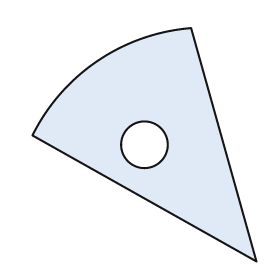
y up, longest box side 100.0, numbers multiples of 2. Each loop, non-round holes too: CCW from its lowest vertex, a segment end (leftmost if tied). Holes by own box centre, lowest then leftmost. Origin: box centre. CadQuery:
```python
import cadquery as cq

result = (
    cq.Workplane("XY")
    .moveTo(48.0, -50.0)
    .lineTo(20.0, 50.0)
    .threePointArc((-20.0, 36.0), (-48.0, 4.0))
    .close()
    .moveTo(0.0, 0.0)
    .circle(10.0)
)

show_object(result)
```